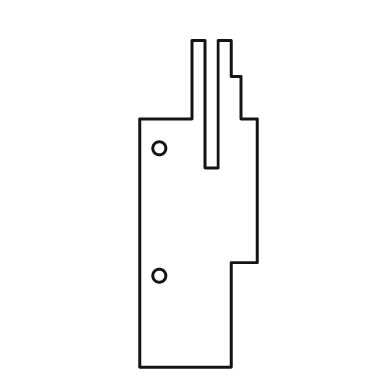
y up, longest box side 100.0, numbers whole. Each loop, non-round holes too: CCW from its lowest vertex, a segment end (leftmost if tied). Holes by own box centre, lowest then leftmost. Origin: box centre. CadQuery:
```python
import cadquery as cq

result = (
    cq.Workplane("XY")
    .moveTo(-18.0, -50.0)
    .lineTo(10.0, -50.0)
    .lineTo(10.0, -18.0)
    .lineTo(18.0, -18.0)
    .lineTo(18.0, 26.0)
    .lineTo(13.0, 26.0)
    .lineTo(13.0, 39.0)
    .lineTo(10.0, 39.0)
    .lineTo(10.0, 50.0)
    .lineTo(6.0, 50.0)
    .lineTo(6.0, 11.0)
    .lineTo(2.0, 11.0)
    .lineTo(2.0, 50.0)
    .lineTo(-2.0, 50.0)
    .lineTo(-2.0, 26.0)
    .lineTo(-18.0, 26.0)
    .close()
    .moveTo(-12.0, -22.0)
    .circle(2.0)
    .moveTo(-12.0, 17.0)
    .circle(2.0)
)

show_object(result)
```